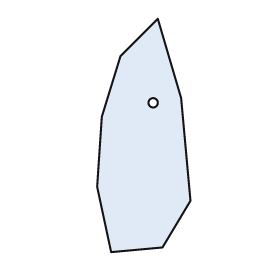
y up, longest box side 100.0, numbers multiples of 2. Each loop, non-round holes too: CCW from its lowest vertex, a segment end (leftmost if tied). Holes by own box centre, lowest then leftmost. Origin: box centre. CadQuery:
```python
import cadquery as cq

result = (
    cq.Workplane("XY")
    .moveTo(-14.0, -50.0)
    .lineTo(8.0, -48.0)
    .lineTo(20.0, -28.0)
    .lineTo(16.0, 16.0)
    .lineTo(6.0, 50.0)
    .lineTo(-10.0, 34.0)
    .lineTo(-18.0, 8.0)
    .lineTo(-20.0, -22.0)
    .close()
    .moveTo(4.0, 14.0)
    .circle(2.0)
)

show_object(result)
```